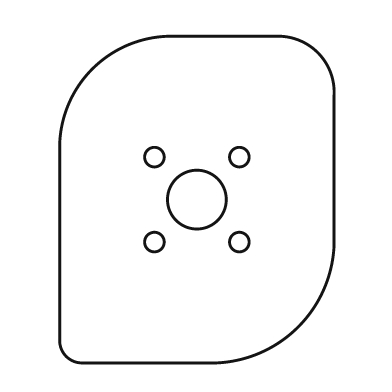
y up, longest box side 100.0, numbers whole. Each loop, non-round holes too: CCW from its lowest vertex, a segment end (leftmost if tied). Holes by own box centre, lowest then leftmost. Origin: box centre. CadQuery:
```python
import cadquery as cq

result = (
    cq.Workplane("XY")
    .moveTo(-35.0, -50.0)
    .lineTo(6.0, -50.0)
    .threePointArc((31.0, -39.0), (42.0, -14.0))
    .lineTo(42.0, 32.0)
    .threePointArc((37.0, 45.0), (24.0, 50.0))
    .lineTo(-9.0, 50.0)
    .threePointArc((-32.0, 40.0), (-42.0, 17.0))
    .lineTo(-42.0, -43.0)
    .threePointArc((-40.0, -48.0), (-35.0, -50.0))
    .close()
    .moveTo(-13.0, -13.0)
    .circle(3.0)
    .moveTo(13.0, -13.0)
    .circle(3.0)
    .moveTo(0.0, 0.0)
    .circle(9.0)
    .moveTo(-13.0, 13.0)
    .circle(3.0)
    .moveTo(13.0, 13.0)
    .circle(3.0)
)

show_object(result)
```